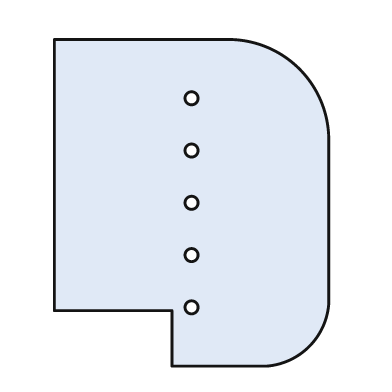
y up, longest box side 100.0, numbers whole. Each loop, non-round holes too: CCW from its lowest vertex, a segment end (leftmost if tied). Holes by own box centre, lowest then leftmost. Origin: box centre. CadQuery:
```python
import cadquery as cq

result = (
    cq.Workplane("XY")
    .moveTo(-6.0, -50.0)
    .lineTo(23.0, -50.0)
    .threePointArc((36.0, -44.0), (42.0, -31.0))
    .lineTo(42.0, 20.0)
    .threePointArc((33.0, 41.0), (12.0, 50.0))
    .lineTo(-42.0, 50.0)
    .lineTo(-42.0, -33.0)
    .lineTo(-6.0, -33.0)
    .close()
    .moveTo(0.0, -32.0)
    .circle(2.0)
    .moveTo(0.0, -16.0)
    .circle(2.0)
    .moveTo(0.0, 0.0)
    .circle(2.0)
    .moveTo(0.0, 16.0)
    .circle(2.0)
    .moveTo(0.0, 32.0)
    .circle(2.0)
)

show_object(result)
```